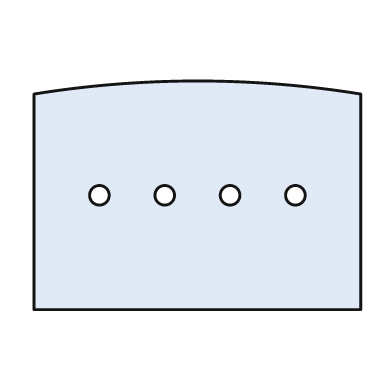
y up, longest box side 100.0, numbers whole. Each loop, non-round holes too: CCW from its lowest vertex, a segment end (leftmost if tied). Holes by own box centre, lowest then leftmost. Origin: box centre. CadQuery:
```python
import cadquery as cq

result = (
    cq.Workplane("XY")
    .moveTo(-50.0, -35.0)
    .lineTo(50.0, -35.0)
    .lineTo(50.0, 31.0)
    .threePointArc((0.0, 35.0), (-50.0, 31.0))
    .close()
    .moveTo(-30.0, 0.0)
    .circle(3.0)
    .moveTo(-10.0, 0.0)
    .circle(3.0)
    .moveTo(10.0, 0.0)
    .circle(3.0)
    .moveTo(30.0, 0.0)
    .circle(3.0)
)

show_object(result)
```